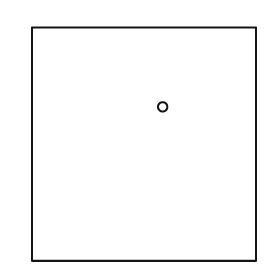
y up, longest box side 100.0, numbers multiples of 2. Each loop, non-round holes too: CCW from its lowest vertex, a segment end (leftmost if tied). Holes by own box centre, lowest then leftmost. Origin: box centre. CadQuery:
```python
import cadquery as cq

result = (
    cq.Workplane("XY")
    .moveTo(-48.0, -50.0)
    .lineTo(48.0, -50.0)
    .lineTo(48.0, 50.0)
    .lineTo(-48.0, 50.0)
    .close()
    .moveTo(8.0, 16.0)
    .circle(2.0)
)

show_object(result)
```